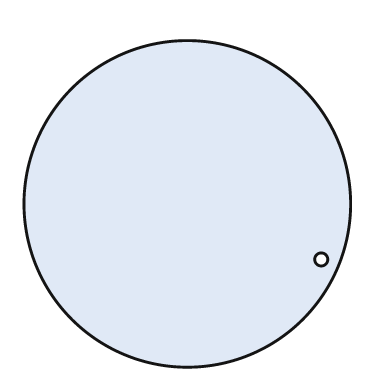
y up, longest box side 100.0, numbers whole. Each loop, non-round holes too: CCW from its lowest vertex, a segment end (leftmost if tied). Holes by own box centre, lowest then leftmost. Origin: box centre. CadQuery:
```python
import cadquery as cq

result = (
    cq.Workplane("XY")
    .moveTo(0.0, 0.0)
    .circle(50.0)
    .moveTo(41.0, -17.0)
    .circle(2.0)
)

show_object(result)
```